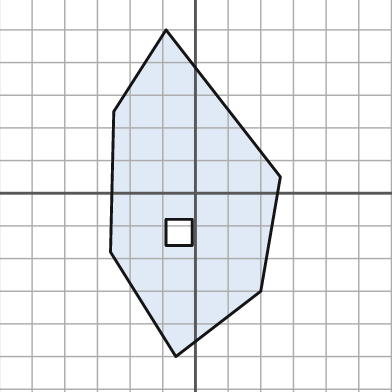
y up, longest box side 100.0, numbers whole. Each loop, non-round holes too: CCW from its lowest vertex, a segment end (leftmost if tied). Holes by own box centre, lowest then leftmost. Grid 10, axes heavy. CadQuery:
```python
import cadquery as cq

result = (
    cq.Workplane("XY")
    .moveTo(-6.0, -50.0)
    .lineTo(20.0, -30.0)
    .lineTo(26.0, 5.0)
    .lineTo(-9.0, 50.0)
    .lineTo(-25.0, 25.0)
    .lineTo(-26.0, -18.0)
    .close()
    .moveTo(-9.0, -16.0)
    .lineTo(-1.0, -16.0)
    .lineTo(-1.0, -8.0)
    .lineTo(-9.0, -8.0)
    .close()
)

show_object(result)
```